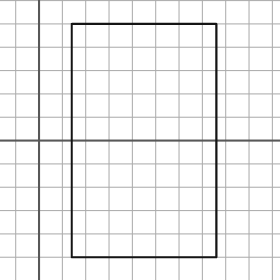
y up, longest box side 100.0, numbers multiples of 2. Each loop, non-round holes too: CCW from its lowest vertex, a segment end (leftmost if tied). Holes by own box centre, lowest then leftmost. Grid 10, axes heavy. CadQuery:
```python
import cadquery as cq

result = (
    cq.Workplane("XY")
    .moveTo(14.0, -50.0)
    .lineTo(76.0, -50.0)
    .lineTo(76.0, 50.0)
    .lineTo(14.0, 50.0)
    .close()
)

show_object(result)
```